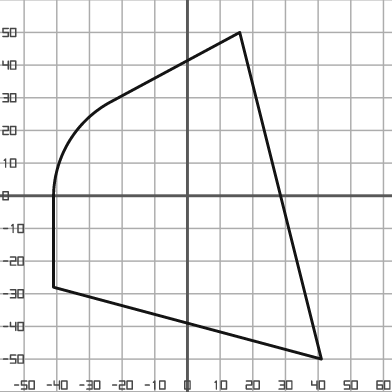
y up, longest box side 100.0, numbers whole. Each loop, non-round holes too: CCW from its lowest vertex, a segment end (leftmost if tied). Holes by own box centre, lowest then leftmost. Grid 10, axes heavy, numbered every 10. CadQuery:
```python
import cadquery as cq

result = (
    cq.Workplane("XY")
    .moveTo(41.0, -50.0)
    .lineTo(16.0, 50.0)
    .lineTo(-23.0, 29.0)
    .threePointArc((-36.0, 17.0), (-41.0, 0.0))
    .lineTo(-41.0, -28.0)
    .close()
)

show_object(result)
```